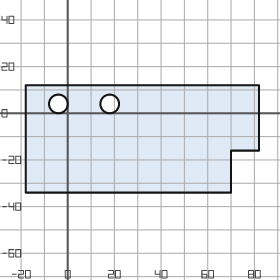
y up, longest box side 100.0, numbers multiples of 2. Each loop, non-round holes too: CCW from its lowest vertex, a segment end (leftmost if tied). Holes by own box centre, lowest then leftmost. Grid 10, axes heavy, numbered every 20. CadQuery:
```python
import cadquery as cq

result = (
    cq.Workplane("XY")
    .moveTo(-18.0, -34.0)
    .lineTo(70.0, -34.0)
    .lineTo(70.0, -16.0)
    .lineTo(82.0, -16.0)
    .lineTo(82.0, 12.0)
    .lineTo(-18.0, 12.0)
    .close()
    .moveTo(-4.0, 4.0)
    .circle(4.0)
    .moveTo(18.0, 4.0)
    .circle(4.0)
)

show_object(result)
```